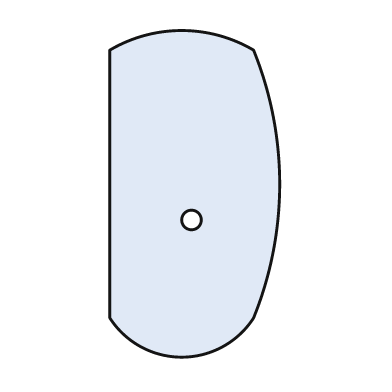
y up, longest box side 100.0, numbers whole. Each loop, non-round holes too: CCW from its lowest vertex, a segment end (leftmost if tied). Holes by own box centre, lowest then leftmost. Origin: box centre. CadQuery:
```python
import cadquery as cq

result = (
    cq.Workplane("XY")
    .moveTo(-26.0, -38.0)
    .threePointArc((-4.0, -50.0), (18.0, -38.0))
    .threePointArc((26.0, 3.0), (18.0, 44.0))
    .threePointArc((-4.0, 50.0), (-26.0, 44.0))
    .close()
    .moveTo(-1.0, -8.0)
    .circle(3.0)
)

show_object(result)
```